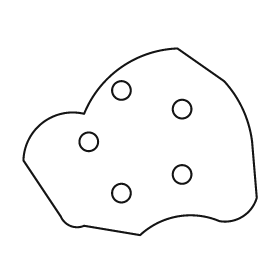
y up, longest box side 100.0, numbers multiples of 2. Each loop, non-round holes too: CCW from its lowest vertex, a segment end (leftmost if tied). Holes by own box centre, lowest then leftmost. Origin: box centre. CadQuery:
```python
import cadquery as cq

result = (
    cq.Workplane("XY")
    .moveTo(0.0, -40.0)
    .threePointArc((16.0, -32.0), (34.0, -34.0))
    .threePointArc((44.0, -32.0), (50.0, -24.0))
    .lineTo(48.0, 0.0)
    .threePointArc((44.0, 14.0), (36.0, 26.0))
    .lineTo(16.0, 40.0)
    .threePointArc((-8.0, 32.0), (-24.0, 12.0))
    .threePointArc((-42.0, 8.0), (-50.0, -8.0))
    .lineTo(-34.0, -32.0)
    .threePointArc((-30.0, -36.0), (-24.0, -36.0))
    .close()
    .moveTo(-8.0, -22.0)
    .circle(4.0)
    .moveTo(18.0, -14.0)
    .circle(4.0)
    .moveTo(-22.0, 0.0)
    .circle(4.0)
    .moveTo(18.0, 14.0)
    .circle(4.0)
    .moveTo(-8.0, 22.0)
    .circle(4.0)
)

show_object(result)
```